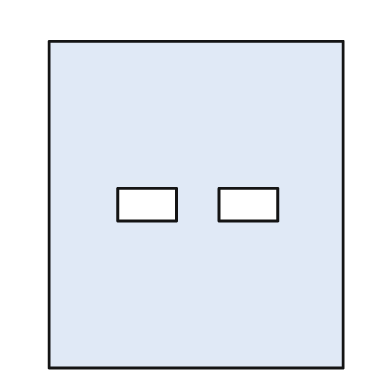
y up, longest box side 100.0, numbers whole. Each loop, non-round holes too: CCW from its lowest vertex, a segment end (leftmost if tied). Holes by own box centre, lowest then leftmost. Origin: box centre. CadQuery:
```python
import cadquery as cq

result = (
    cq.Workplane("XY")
    .moveTo(-45.0, -50.0)
    .lineTo(45.0, -50.0)
    .lineTo(45.0, 50.0)
    .lineTo(-45.0, 50.0)
    .close()
    .moveTo(-24.0, -5.0)
    .lineTo(-6.0, -5.0)
    .lineTo(-6.0, 5.0)
    .lineTo(-24.0, 5.0)
    .close()
    .moveTo(7.0, -5.0)
    .lineTo(25.0, -5.0)
    .lineTo(25.0, 5.0)
    .lineTo(7.0, 5.0)
    .close()
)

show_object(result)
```